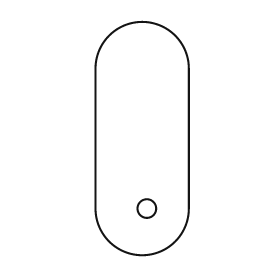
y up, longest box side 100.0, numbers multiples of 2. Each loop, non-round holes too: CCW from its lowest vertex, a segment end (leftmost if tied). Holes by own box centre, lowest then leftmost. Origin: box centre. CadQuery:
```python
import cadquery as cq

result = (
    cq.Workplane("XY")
    .moveTo(-20.0, -30.0)
    .threePointArc((0.0, -50.0), (20.0, -30.0))
    .lineTo(20.0, 30.0)
    .threePointArc((0.0, 50.0), (-20.0, 30.0))
    .close()
    .moveTo(2.0, -30.0)
    .circle(4.0)
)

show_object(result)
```